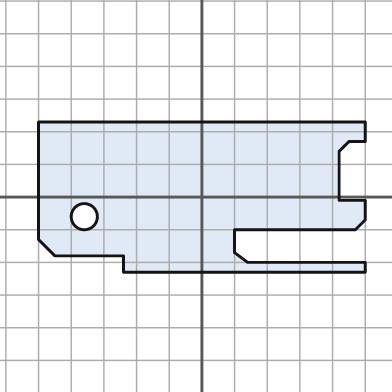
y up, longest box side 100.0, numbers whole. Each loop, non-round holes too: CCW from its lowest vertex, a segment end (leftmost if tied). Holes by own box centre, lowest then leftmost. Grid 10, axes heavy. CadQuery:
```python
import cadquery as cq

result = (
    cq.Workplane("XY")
    .moveTo(-24.0, -23.0)
    .lineTo(50.0, -23.0)
    .lineTo(50.0, -20.0)
    .lineTo(14.0, -20.0)
    .lineTo(10.0, -17.0)
    .lineTo(10.0, -10.0)
    .lineTo(47.0, -10.0)
    .lineTo(50.0, -7.0)
    .lineTo(50.0, -1.0)
    .lineTo(42.0, -1.0)
    .lineTo(42.0, 14.0)
    .lineTo(45.0, 17.0)
    .lineTo(50.0, 17.0)
    .lineTo(50.0, 23.0)
    .lineTo(-50.0, 23.0)
    .lineTo(-50.0, -13.0)
    .lineTo(-45.0, -18.0)
    .lineTo(-24.0, -18.0)
    .close()
    .moveTo(-36.0, -6.0)
    .circle(4.0)
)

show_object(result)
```